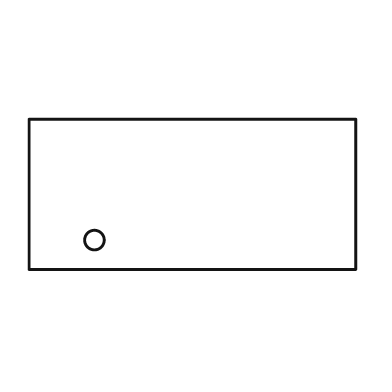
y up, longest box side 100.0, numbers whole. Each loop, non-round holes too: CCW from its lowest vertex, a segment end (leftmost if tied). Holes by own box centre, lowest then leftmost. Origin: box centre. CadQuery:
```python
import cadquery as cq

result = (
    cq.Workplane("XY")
    .moveTo(-50.0, -23.0)
    .lineTo(50.0, -23.0)
    .lineTo(50.0, 23.0)
    .lineTo(-50.0, 23.0)
    .close()
    .moveTo(-30.0, -14.0)
    .circle(3.0)
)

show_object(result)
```